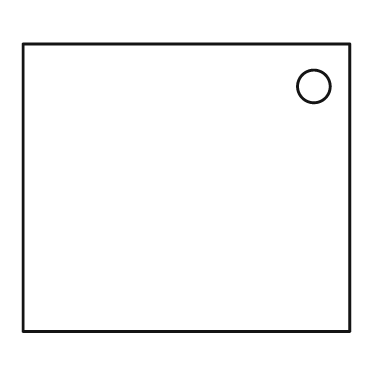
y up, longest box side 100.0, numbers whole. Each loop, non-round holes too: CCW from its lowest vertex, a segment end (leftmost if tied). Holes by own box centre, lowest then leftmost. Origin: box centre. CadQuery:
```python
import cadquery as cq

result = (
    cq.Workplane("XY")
    .moveTo(-50.0, -44.0)
    .lineTo(50.0, -44.0)
    .lineTo(50.0, 44.0)
    .lineTo(-50.0, 44.0)
    .close()
    .moveTo(39.0, 31.0)
    .circle(5.0)
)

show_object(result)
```